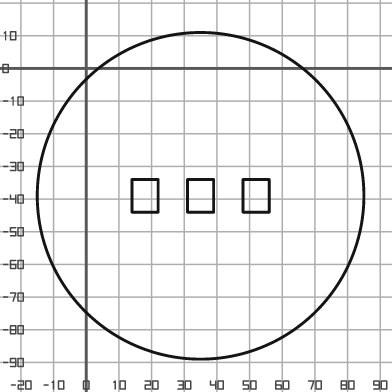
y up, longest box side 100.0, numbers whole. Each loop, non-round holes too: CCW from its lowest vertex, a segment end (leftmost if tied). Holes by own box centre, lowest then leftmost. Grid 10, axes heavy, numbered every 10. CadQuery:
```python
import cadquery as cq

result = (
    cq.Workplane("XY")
    .moveTo(35.0, -39.0)
    .circle(50.0)
    .moveTo(14.0, -44.0)
    .lineTo(22.0, -44.0)
    .lineTo(22.0, -34.0)
    .lineTo(14.0, -34.0)
    .close()
    .moveTo(31.0, -44.0)
    .lineTo(39.0, -44.0)
    .lineTo(39.0, -34.0)
    .lineTo(31.0, -34.0)
    .close()
    .moveTo(48.0, -44.0)
    .lineTo(56.0, -44.0)
    .lineTo(56.0, -34.0)
    .lineTo(48.0, -34.0)
    .close()
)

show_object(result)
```